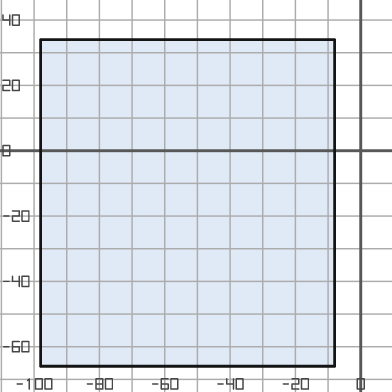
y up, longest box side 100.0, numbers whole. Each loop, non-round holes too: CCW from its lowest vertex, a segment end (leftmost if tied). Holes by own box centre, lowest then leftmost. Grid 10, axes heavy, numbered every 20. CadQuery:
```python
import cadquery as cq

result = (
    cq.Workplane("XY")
    .moveTo(-98.0, -66.0)
    .lineTo(-8.0, -66.0)
    .lineTo(-8.0, 34.0)
    .lineTo(-98.0, 34.0)
    .close()
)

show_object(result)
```